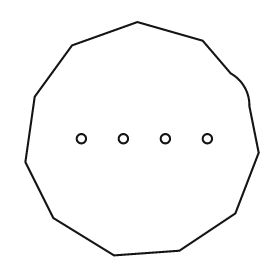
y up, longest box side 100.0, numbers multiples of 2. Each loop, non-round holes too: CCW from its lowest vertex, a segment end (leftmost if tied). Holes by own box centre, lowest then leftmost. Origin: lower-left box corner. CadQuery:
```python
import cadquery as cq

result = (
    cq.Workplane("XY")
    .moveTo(38.0, 0.0)
    .lineTo(66.0, 2.0)
    .lineTo(90.0, 18.0)
    .lineTo(100.0, 44.0)
    .lineTo(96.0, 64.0)
    .threePointArc((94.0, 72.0), (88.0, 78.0))
    .lineTo(76.0, 92.0)
    .lineTo(48.0, 100.0)
    .lineTo(20.0, 90.0)
    .lineTo(4.0, 68.0)
    .lineTo(0.0, 40.0)
    .lineTo(12.0, 16.0)
    .close()
    .moveTo(24.0, 50.0)
    .circle(2.0)
    .moveTo(42.0, 50.0)
    .circle(2.0)
    .moveTo(60.0, 50.0)
    .circle(2.0)
    .moveTo(78.0, 50.0)
    .circle(2.0)
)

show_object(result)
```